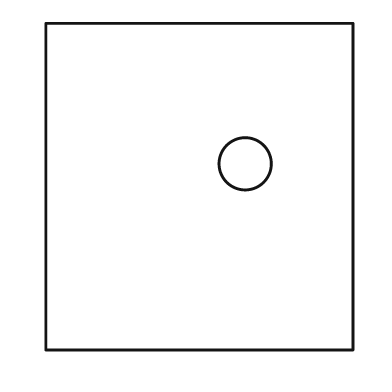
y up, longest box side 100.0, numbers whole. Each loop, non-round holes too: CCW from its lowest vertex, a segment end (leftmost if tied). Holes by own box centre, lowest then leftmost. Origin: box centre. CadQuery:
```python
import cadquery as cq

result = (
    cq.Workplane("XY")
    .moveTo(-47.0, -50.0)
    .lineTo(47.0, -50.0)
    .lineTo(47.0, 50.0)
    .lineTo(-47.0, 50.0)
    .close()
    .moveTo(14.0, 7.0)
    .circle(8.0)
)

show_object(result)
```